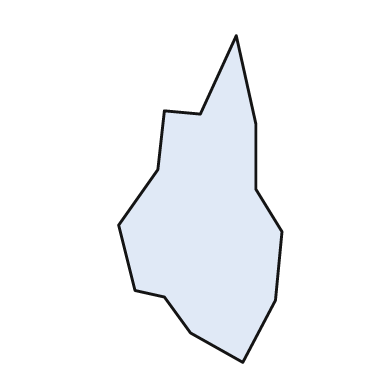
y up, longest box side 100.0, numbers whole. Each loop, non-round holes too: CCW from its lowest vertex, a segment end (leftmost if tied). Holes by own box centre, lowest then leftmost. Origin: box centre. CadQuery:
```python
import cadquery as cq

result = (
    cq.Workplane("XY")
    .moveTo(13.0, -50.0)
    .lineTo(23.0, -31.0)
    .lineTo(25.0, -10.0)
    .lineTo(17.0, 3.0)
    .lineTo(17.0, 23.0)
    .lineTo(11.0, 50.0)
    .lineTo(0.0, 26.0)
    .lineTo(-11.0, 27.0)
    .lineTo(-13.0, 9.0)
    .lineTo(-25.0, -8.0)
    .lineTo(-20.0, -28.0)
    .lineTo(-11.0, -30.0)
    .lineTo(-3.0, -41.0)
    .close()
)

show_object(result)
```